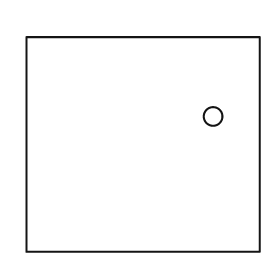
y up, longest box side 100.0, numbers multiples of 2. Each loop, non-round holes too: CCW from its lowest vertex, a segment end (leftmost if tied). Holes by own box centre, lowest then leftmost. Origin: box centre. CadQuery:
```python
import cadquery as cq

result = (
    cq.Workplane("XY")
    .moveTo(-50.0, -46.0)
    .lineTo(50.0, -46.0)
    .lineTo(50.0, 46.0)
    .lineTo(-50.0, 46.0)
    .close()
    .moveTo(30.0, 12.0)
    .circle(4.0)
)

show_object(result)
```